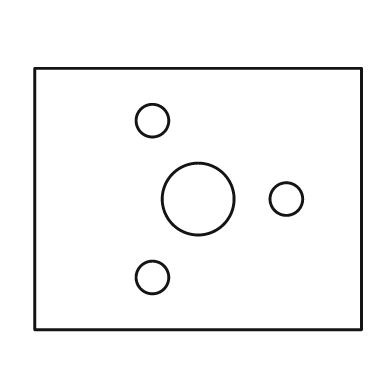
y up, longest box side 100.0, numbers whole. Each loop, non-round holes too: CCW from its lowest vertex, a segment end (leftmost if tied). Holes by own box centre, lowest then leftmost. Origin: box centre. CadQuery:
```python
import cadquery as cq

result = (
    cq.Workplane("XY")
    .moveTo(-50.0, -40.0)
    .lineTo(50.0, -40.0)
    .lineTo(50.0, 40.0)
    .lineTo(-50.0, 40.0)
    .close()
    .moveTo(-14.0, -24.0)
    .circle(5.0)
    .moveTo(0.0, 0.0)
    .circle(11.0)
    .moveTo(27.0, 0.0)
    .circle(5.0)
    .moveTo(-14.0, 24.0)
    .circle(5.0)
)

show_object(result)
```